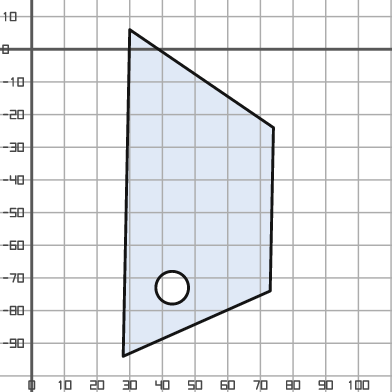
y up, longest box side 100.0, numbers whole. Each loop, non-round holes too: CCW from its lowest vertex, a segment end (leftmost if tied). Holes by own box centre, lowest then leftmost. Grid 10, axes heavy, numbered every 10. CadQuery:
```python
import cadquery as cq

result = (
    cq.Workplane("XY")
    .moveTo(28.0, -94.0)
    .lineTo(73.0, -74.0)
    .lineTo(74.0, -24.0)
    .lineTo(30.0, 6.0)
    .close()
    .moveTo(43.0, -73.0)
    .circle(5.0)
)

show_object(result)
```